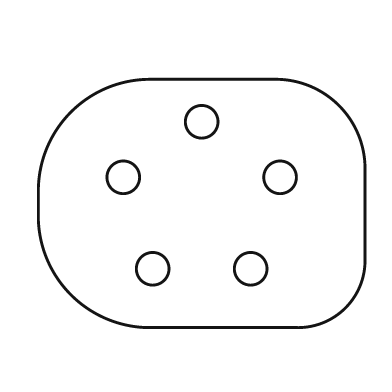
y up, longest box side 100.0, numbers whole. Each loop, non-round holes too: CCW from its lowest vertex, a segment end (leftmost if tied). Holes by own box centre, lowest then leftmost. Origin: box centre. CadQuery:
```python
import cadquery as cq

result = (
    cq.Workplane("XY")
    .moveTo(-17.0, -38.0)
    .lineTo(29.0, -38.0)
    .threePointArc((44.0, -32.0), (50.0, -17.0))
    .lineTo(50.0, 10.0)
    .threePointArc((42.0, 30.0), (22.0, 38.0))
    .lineTo(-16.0, 38.0)
    .threePointArc((-40.0, 28.0), (-50.0, 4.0))
    .lineTo(-50.0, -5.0)
    .threePointArc((-40.0, -28.0), (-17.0, -38.0))
    .close()
    .moveTo(-15.0, -20.0)
    .circle(5.0)
    .moveTo(15.0, -20.0)
    .circle(5.0)
    .moveTo(-24.0, 8.0)
    .circle(5.0)
    .moveTo(24.0, 8.0)
    .circle(5.0)
    .moveTo(0.0, 25.0)
    .circle(5.0)
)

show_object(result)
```